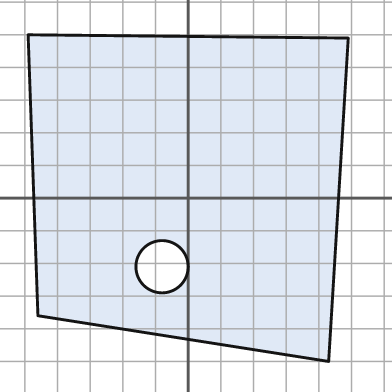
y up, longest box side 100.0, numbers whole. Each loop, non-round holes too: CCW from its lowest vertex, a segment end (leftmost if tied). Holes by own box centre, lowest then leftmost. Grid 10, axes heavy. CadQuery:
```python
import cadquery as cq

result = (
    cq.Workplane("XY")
    .moveTo(43.0, -50.0)
    .lineTo(49.0, 49.0)
    .lineTo(-49.0, 50.0)
    .lineTo(-46.0, -36.0)
    .close()
    .moveTo(-8.0, -21.0)
    .circle(8.0)
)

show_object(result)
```